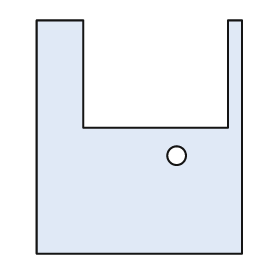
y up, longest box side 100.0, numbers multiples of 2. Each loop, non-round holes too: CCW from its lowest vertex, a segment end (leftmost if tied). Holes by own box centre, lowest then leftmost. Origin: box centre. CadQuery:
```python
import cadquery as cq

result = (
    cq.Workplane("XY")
    .moveTo(-44.0, -50.0)
    .lineTo(44.0, -50.0)
    .lineTo(44.0, 50.0)
    .lineTo(38.0, 50.0)
    .lineTo(38.0, 4.0)
    .lineTo(-24.0, 4.0)
    .lineTo(-24.0, 50.0)
    .lineTo(-44.0, 50.0)
    .close()
    .moveTo(16.0, -8.0)
    .circle(4.0)
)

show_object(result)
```